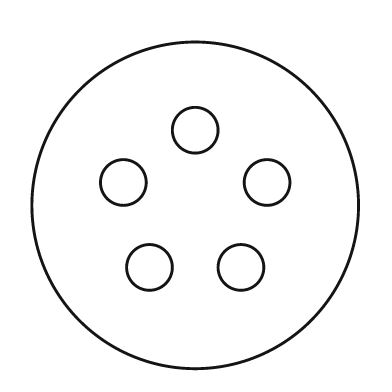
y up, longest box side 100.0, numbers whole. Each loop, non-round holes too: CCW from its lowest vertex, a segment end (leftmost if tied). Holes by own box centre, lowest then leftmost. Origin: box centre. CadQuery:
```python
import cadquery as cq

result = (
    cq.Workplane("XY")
    .moveTo(0.0, 0.0)
    .circle(50.0)
    .moveTo(-14.0, -19.0)
    .circle(7.0)
    .moveTo(14.0, -19.0)
    .circle(7.0)
    .moveTo(-22.0, 7.0)
    .circle(7.0)
    .moveTo(22.0, 7.0)
    .circle(7.0)
    .moveTo(0.0, 23.0)
    .circle(7.0)
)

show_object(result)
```